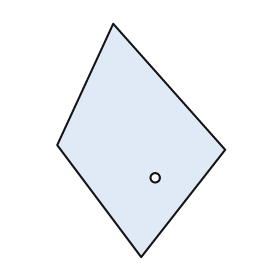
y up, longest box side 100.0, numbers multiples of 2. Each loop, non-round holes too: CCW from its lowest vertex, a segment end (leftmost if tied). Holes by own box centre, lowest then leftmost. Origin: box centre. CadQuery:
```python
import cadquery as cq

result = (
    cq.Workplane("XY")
    .moveTo(0.0, -50.0)
    .lineTo(36.0, -4.0)
    .lineTo(-12.0, 50.0)
    .lineTo(-36.0, -2.0)
    .close()
    .moveTo(6.0, -16.0)
    .circle(2.0)
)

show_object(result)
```